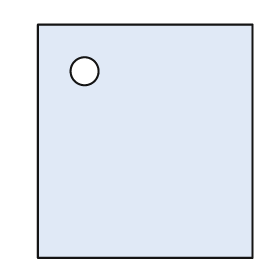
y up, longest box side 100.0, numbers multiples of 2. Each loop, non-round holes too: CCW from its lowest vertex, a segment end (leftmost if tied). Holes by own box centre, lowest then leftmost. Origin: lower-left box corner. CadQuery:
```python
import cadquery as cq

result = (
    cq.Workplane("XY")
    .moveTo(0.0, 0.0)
    .lineTo(92.0, 0.0)
    .lineTo(92.0, 100.0)
    .lineTo(0.0, 100.0)
    .close()
    .moveTo(20.0, 80.0)
    .circle(6.0)
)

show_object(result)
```